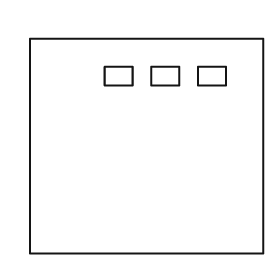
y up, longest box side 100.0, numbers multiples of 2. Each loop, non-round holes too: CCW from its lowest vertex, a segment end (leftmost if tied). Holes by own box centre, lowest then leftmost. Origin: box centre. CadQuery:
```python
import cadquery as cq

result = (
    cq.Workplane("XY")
    .moveTo(-50.0, -46.0)
    .lineTo(50.0, -46.0)
    .lineTo(50.0, 46.0)
    .lineTo(-50.0, 46.0)
    .close()
    .moveTo(-18.0, 26.0)
    .lineTo(-6.0, 26.0)
    .lineTo(-6.0, 34.0)
    .lineTo(-18.0, 34.0)
    .close()
    .moveTo(2.0, 26.0)
    .lineTo(14.0, 26.0)
    .lineTo(14.0, 34.0)
    .lineTo(2.0, 34.0)
    .close()
    .moveTo(22.0, 26.0)
    .lineTo(34.0, 26.0)
    .lineTo(34.0, 34.0)
    .lineTo(22.0, 34.0)
    .close()
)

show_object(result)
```